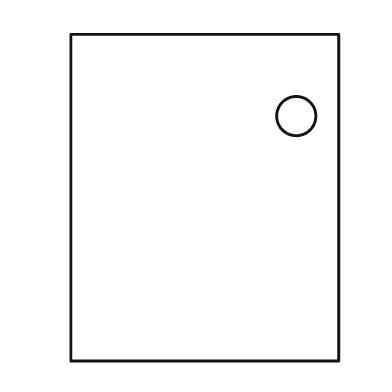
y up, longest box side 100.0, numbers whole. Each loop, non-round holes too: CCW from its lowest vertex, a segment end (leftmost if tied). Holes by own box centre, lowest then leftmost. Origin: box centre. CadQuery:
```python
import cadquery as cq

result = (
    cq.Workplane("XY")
    .moveTo(-41.0, -50.0)
    .lineTo(41.0, -50.0)
    .lineTo(41.0, 50.0)
    .lineTo(-41.0, 50.0)
    .close()
    .moveTo(28.0, 25.0)
    .circle(6.0)
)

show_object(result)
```